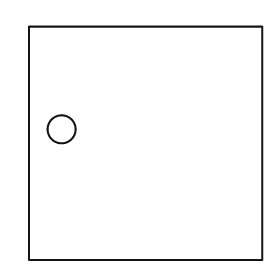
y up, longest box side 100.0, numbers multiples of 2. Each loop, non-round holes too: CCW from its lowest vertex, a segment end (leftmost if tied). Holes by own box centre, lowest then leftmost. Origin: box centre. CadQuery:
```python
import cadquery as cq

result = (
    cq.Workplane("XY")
    .moveTo(-50.0, -50.0)
    .lineTo(50.0, -50.0)
    .lineTo(50.0, 50.0)
    .lineTo(-50.0, 50.0)
    .close()
    .moveTo(-36.0, 6.0)
    .circle(6.0)
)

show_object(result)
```